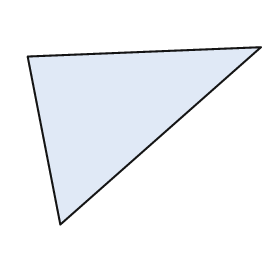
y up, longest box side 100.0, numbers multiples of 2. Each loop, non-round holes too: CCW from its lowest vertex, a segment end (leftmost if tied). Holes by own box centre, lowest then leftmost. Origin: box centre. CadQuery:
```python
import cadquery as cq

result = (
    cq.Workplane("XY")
    .moveTo(-36.0, -38.0)
    .lineTo(50.0, 38.0)
    .lineTo(-50.0, 34.0)
    .close()
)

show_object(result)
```